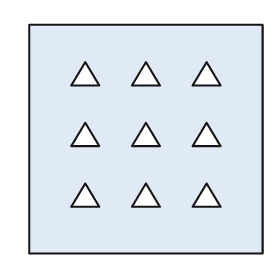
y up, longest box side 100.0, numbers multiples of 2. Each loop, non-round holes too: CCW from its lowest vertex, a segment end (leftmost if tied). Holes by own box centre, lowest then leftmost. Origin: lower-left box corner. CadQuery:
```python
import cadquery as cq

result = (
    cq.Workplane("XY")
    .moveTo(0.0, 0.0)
    .lineTo(100.0, 0.0)
    .lineTo(100.0, 98.0)
    .lineTo(0.0, 98.0)
    .close()
    .moveTo(18.0, 20.0)
    .lineTo(30.0, 20.0)
    .lineTo(24.0, 30.0)
    .close()
    .moveTo(44.0, 20.0)
    .lineTo(56.0, 20.0)
    .lineTo(50.0, 30.0)
    .close()
    .moveTo(70.0, 20.0)
    .lineTo(82.0, 20.0)
    .lineTo(76.0, 30.0)
    .close()
    .moveTo(18.0, 46.0)
    .lineTo(30.0, 46.0)
    .lineTo(24.0, 56.0)
    .close()
    .moveTo(44.0, 46.0)
    .lineTo(56.0, 46.0)
    .lineTo(50.0, 56.0)
    .close()
    .moveTo(70.0, 46.0)
    .lineTo(82.0, 46.0)
    .lineTo(76.0, 56.0)
    .close()
    .moveTo(18.0, 72.0)
    .lineTo(30.0, 72.0)
    .lineTo(24.0, 82.0)
    .close()
    .moveTo(44.0, 72.0)
    .lineTo(56.0, 72.0)
    .lineTo(50.0, 82.0)
    .close()
    .moveTo(70.0, 72.0)
    .lineTo(82.0, 72.0)
    .lineTo(76.0, 82.0)
    .close()
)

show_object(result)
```